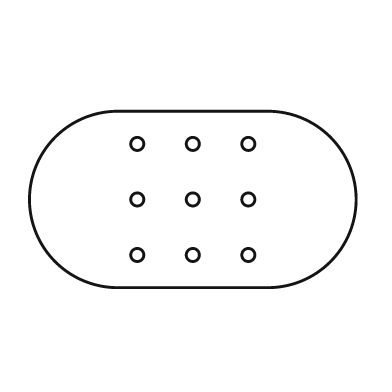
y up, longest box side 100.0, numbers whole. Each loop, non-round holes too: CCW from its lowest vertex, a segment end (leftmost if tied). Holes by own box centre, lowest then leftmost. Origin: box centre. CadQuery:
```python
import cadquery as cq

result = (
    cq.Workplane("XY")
    .moveTo(-23.0, -27.0)
    .lineTo(23.0, -27.0)
    .threePointArc((50.0, 0.0), (23.0, 27.0))
    .lineTo(-23.0, 27.0)
    .threePointArc((-50.0, 0.0), (-23.0, -27.0))
    .close()
    .moveTo(-17.0, -17.0)
    .circle(2.0)
    .moveTo(0.0, -17.0)
    .circle(2.0)
    .moveTo(17.0, -17.0)
    .circle(2.0)
    .moveTo(-17.0, 0.0)
    .circle(2.0)
    .moveTo(0.0, 0.0)
    .circle(2.0)
    .moveTo(17.0, 0.0)
    .circle(2.0)
    .moveTo(-17.0, 17.0)
    .circle(2.0)
    .moveTo(0.0, 17.0)
    .circle(2.0)
    .moveTo(17.0, 17.0)
    .circle(2.0)
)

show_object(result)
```